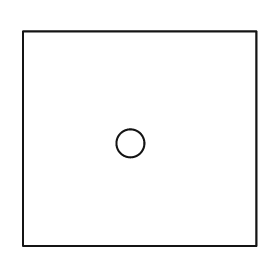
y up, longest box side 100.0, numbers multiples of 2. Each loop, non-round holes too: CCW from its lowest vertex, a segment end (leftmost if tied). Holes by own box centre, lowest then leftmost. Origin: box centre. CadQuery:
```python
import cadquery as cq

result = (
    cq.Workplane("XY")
    .moveTo(-50.0, -46.0)
    .lineTo(50.0, -46.0)
    .lineTo(50.0, 46.0)
    .lineTo(-50.0, 46.0)
    .close()
    .moveTo(-4.0, -2.0)
    .circle(6.0)
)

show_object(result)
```